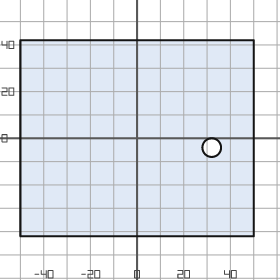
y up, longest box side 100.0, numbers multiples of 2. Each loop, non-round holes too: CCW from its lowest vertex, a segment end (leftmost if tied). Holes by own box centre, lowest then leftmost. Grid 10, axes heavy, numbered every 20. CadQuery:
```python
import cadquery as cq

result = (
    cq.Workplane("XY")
    .moveTo(-50.0, -42.0)
    .lineTo(50.0, -42.0)
    .lineTo(50.0, 42.0)
    .lineTo(-50.0, 42.0)
    .close()
    .moveTo(32.0, -4.0)
    .circle(4.0)
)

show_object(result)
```